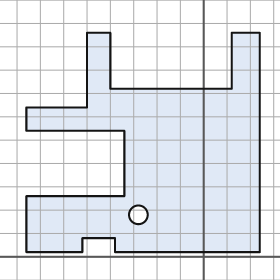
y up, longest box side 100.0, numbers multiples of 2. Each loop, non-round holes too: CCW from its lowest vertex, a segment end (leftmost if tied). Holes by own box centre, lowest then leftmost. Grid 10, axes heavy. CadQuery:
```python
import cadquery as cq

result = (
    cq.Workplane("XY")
    .moveTo(-76.0, 2.0)
    .lineTo(-52.0, 2.0)
    .lineTo(-52.0, 8.0)
    .lineTo(-38.0, 8.0)
    .lineTo(-38.0, 2.0)
    .lineTo(24.0, 2.0)
    .lineTo(24.0, 96.0)
    .lineTo(12.0, 96.0)
    .lineTo(12.0, 72.0)
    .lineTo(-40.0, 72.0)
    .lineTo(-40.0, 96.0)
    .lineTo(-50.0, 96.0)
    .lineTo(-50.0, 64.0)
    .lineTo(-76.0, 64.0)
    .lineTo(-76.0, 54.0)
    .lineTo(-34.0, 54.0)
    .lineTo(-34.0, 26.0)
    .lineTo(-76.0, 26.0)
    .close()
    .moveTo(-28.0, 18.0)
    .circle(4.0)
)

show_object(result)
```